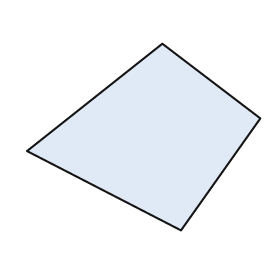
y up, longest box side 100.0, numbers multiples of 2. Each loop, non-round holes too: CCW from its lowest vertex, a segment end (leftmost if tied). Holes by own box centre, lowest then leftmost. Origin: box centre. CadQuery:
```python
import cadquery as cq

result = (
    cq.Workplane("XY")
    .moveTo(16.0, -40.0)
    .lineTo(50.0, 8.0)
    .lineTo(8.0, 40.0)
    .lineTo(-50.0, -6.0)
    .close()
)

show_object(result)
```